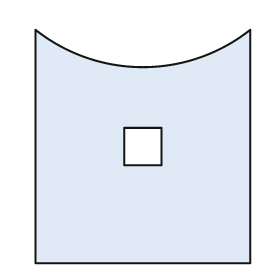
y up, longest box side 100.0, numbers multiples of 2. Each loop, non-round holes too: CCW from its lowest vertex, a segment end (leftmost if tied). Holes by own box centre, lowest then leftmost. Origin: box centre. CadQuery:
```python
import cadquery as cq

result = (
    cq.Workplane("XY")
    .moveTo(-46.0, -50.0)
    .lineTo(46.0, -50.0)
    .lineTo(46.0, 50.0)
    .threePointArc((0.0, 34.0), (-46.0, 50.0))
    .close()
    .moveTo(-8.0, -8.0)
    .lineTo(8.0, -8.0)
    .lineTo(8.0, 8.0)
    .lineTo(-8.0, 8.0)
    .close()
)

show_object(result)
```